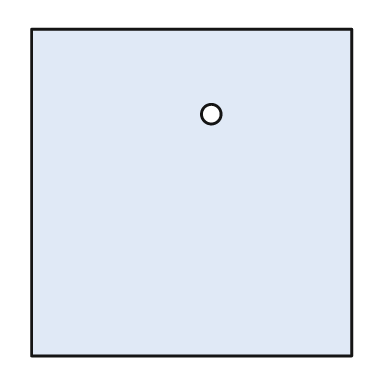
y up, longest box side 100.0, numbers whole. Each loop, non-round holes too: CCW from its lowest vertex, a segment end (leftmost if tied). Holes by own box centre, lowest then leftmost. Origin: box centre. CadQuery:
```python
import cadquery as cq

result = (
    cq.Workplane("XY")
    .moveTo(-49.0, -50.0)
    .lineTo(49.0, -50.0)
    .lineTo(49.0, 50.0)
    .lineTo(-49.0, 50.0)
    .close()
    .moveTo(6.0, 24.0)
    .circle(3.0)
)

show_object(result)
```